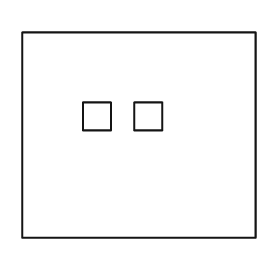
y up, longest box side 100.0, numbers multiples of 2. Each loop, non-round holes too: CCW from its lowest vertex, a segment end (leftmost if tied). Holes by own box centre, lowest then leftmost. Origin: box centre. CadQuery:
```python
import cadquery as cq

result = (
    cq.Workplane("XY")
    .moveTo(-50.0, -44.0)
    .lineTo(50.0, -44.0)
    .lineTo(50.0, 44.0)
    .lineTo(-50.0, 44.0)
    .close()
    .moveTo(-24.0, 2.0)
    .lineTo(-12.0, 2.0)
    .lineTo(-12.0, 14.0)
    .lineTo(-24.0, 14.0)
    .close()
    .moveTo(-2.0, 2.0)
    .lineTo(10.0, 2.0)
    .lineTo(10.0, 14.0)
    .lineTo(-2.0, 14.0)
    .close()
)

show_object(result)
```